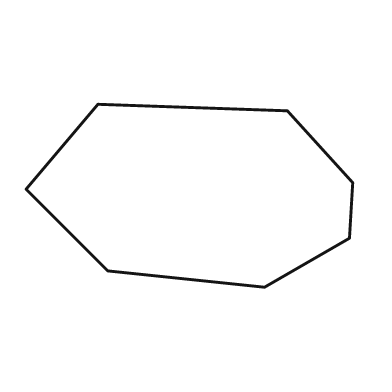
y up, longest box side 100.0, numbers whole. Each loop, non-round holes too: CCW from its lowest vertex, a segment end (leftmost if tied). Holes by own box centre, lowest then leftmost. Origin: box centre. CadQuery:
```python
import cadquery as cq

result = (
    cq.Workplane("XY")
    .moveTo(23.0, -28.0)
    .lineTo(49.0, -13.0)
    .lineTo(50.0, 4.0)
    .lineTo(30.0, 26.0)
    .lineTo(-28.0, 28.0)
    .lineTo(-50.0, 2.0)
    .lineTo(-25.0, -23.0)
    .close()
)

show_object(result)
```